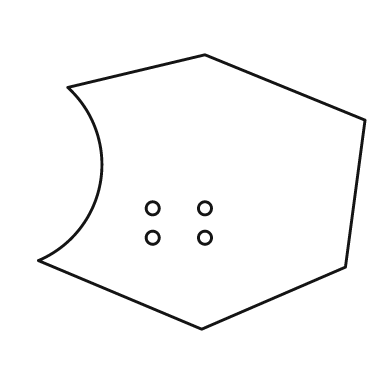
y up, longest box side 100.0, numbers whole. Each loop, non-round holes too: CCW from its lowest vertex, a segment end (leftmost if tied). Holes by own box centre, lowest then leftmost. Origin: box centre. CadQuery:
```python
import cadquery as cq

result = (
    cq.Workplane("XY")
    .moveTo(0.0, -42.0)
    .lineTo(44.0, -23.0)
    .lineTo(50.0, 22.0)
    .lineTo(1.0, 42.0)
    .lineTo(-41.0, 32.0)
    .threePointArc((-31.0, 3.0), (-50.0, -21.0))
    .close()
    .moveTo(-15.0, -14.0)
    .circle(2.0)
    .moveTo(1.0, -14.0)
    .circle(2.0)
    .moveTo(-15.0, -5.0)
    .circle(2.0)
    .moveTo(1.0, -5.0)
    .circle(2.0)
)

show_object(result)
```